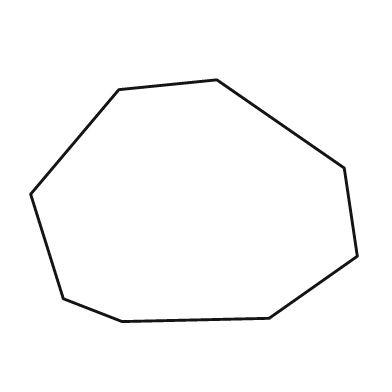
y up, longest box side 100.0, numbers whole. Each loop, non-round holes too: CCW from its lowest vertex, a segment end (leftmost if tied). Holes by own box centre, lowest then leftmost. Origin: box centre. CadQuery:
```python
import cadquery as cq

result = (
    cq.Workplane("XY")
    .moveTo(-22.0, -37.0)
    .lineTo(23.0, -36.0)
    .lineTo(50.0, -17.0)
    .lineTo(46.0, 10.0)
    .lineTo(7.0, 37.0)
    .lineTo(-23.0, 34.0)
    .lineTo(-50.0, 2.0)
    .lineTo(-40.0, -30.0)
    .close()
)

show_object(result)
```